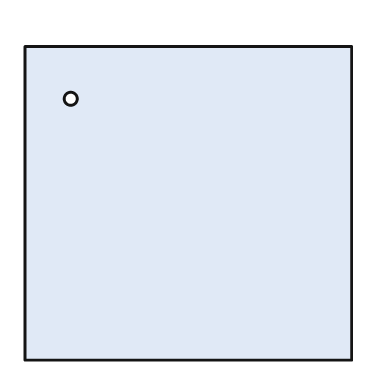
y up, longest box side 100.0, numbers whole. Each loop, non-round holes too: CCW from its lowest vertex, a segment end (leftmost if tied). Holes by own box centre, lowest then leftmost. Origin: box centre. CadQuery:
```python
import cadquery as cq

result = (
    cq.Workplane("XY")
    .moveTo(-50.0, -48.0)
    .lineTo(50.0, -48.0)
    .lineTo(50.0, 48.0)
    .lineTo(-50.0, 48.0)
    .close()
    .moveTo(-36.0, 32.0)
    .circle(2.0)
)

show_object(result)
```